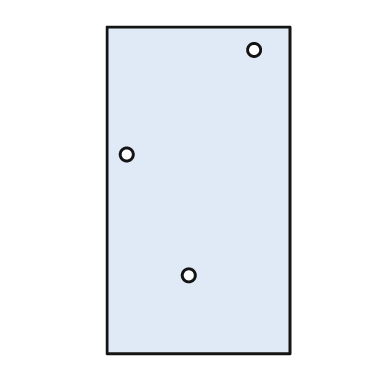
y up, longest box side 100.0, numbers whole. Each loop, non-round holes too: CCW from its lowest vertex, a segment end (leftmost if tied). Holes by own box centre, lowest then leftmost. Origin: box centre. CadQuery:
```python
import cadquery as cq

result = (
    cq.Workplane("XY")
    .moveTo(-28.0, -50.0)
    .lineTo(28.0, -50.0)
    .lineTo(28.0, 50.0)
    .lineTo(-28.0, 50.0)
    .close()
    .moveTo(-3.0, -26.0)
    .circle(2.0)
    .moveTo(-22.0, 11.0)
    .circle(2.0)
    .moveTo(17.0, 43.0)
    .circle(2.0)
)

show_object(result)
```